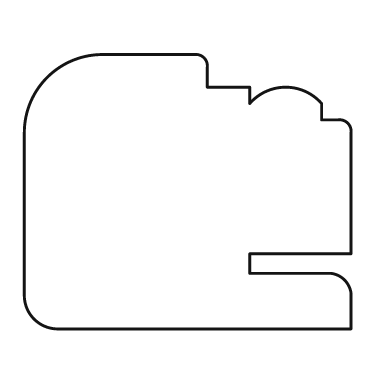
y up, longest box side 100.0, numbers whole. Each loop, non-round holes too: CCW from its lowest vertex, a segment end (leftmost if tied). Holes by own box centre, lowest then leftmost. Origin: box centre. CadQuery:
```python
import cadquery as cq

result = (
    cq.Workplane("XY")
    .moveTo(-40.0, -42.0)
    .lineTo(50.0, -42.0)
    .lineTo(50.0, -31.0)
    .threePointArc((48.0, -27.0), (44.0, -25.0))
    .lineTo(19.0, -25.0)
    .lineTo(19.0, -19.0)
    .lineTo(50.0, -19.0)
    .lineTo(50.0, 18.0)
    .threePointArc((49.0, 21.0), (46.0, 22.0))
    .lineTo(41.0, 22.0)
    .lineTo(41.0, 27.0)
    .threePointArc((30.0, 32.0), (19.0, 27.0))
    .lineTo(19.0, 32.0)
    .lineTo(6.0, 32.0)
    .lineTo(6.0, 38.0)
    .threePointArc((5.0, 41.0), (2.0, 42.0))
    .lineTo(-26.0, 42.0)
    .threePointArc((-43.0, 35.0), (-50.0, 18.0))
    .lineTo(-50.0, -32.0)
    .threePointArc((-47.0, -39.0), (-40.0, -42.0))
    .close()
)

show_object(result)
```